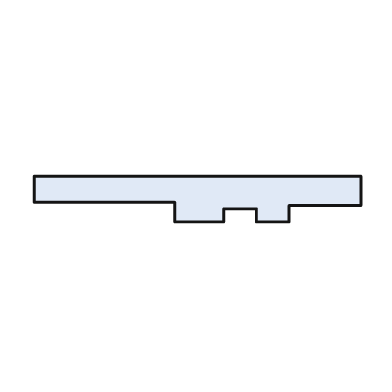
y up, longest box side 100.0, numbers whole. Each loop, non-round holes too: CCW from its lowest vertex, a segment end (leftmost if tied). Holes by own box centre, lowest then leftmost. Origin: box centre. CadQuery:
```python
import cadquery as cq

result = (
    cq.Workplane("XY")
    .moveTo(-7.0, -7.0)
    .lineTo(8.0, -7.0)
    .lineTo(8.0, -3.0)
    .lineTo(18.0, -3.0)
    .lineTo(18.0, -7.0)
    .lineTo(28.0, -7.0)
    .lineTo(28.0, -2.0)
    .lineTo(50.0, -2.0)
    .lineTo(50.0, 7.0)
    .lineTo(-50.0, 7.0)
    .lineTo(-50.0, -1.0)
    .lineTo(-7.0, -1.0)
    .close()
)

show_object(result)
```